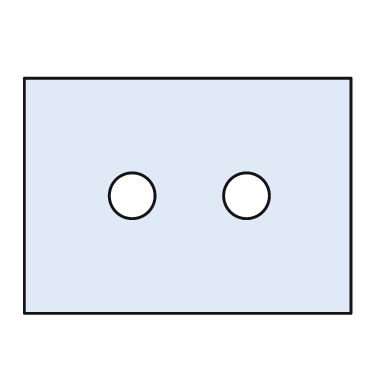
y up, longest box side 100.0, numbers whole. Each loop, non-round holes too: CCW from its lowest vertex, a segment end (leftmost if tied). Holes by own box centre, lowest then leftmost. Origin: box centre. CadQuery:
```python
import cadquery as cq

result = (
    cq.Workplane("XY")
    .moveTo(-50.0, -36.0)
    .lineTo(50.0, -36.0)
    .lineTo(50.0, 36.0)
    .lineTo(-50.0, 36.0)
    .close()
    .moveTo(-17.0, 0.0)
    .circle(7.0)
    .moveTo(18.0, 0.0)
    .circle(7.0)
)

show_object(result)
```